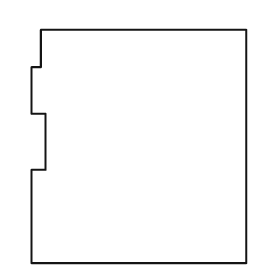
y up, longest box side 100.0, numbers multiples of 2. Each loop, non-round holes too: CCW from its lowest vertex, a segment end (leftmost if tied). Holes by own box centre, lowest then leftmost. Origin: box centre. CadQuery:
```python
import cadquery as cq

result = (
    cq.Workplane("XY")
    .moveTo(-46.0, -50.0)
    .lineTo(46.0, -50.0)
    .lineTo(46.0, 50.0)
    .lineTo(-42.0, 50.0)
    .lineTo(-42.0, 34.0)
    .lineTo(-46.0, 34.0)
    .lineTo(-46.0, 14.0)
    .lineTo(-40.0, 14.0)
    .lineTo(-40.0, -10.0)
    .lineTo(-46.0, -10.0)
    .close()
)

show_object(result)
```